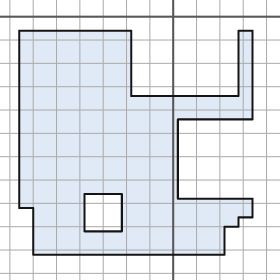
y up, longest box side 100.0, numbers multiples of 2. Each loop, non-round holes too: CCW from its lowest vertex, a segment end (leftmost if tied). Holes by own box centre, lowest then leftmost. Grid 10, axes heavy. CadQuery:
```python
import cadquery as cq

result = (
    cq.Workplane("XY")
    .moveTo(-60.0, -102.0)
    .lineTo(22.0, -102.0)
    .lineTo(22.0, -90.0)
    .lineTo(28.0, -90.0)
    .lineTo(28.0, -86.0)
    .lineTo(34.0, -86.0)
    .lineTo(34.0, -78.0)
    .lineTo(2.0, -78.0)
    .lineTo(2.0, -44.0)
    .lineTo(34.0, -44.0)
    .lineTo(34.0, -6.0)
    .lineTo(28.0, -6.0)
    .lineTo(28.0, -34.0)
    .lineTo(-18.0, -34.0)
    .lineTo(-18.0, -6.0)
    .lineTo(-66.0, -6.0)
    .lineTo(-66.0, -82.0)
    .lineTo(-60.0, -82.0)
    .close()
    .moveTo(-38.0, -92.0)
    .lineTo(-22.0, -92.0)
    .lineTo(-22.0, -76.0)
    .lineTo(-38.0, -76.0)
    .close()
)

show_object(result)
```